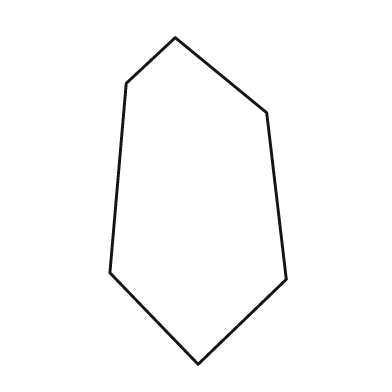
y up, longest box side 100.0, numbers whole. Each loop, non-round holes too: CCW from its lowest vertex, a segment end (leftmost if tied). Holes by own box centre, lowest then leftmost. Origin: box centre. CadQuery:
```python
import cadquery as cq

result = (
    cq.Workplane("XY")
    .moveTo(0.0, -50.0)
    .lineTo(27.0, -24.0)
    .lineTo(21.0, 27.0)
    .lineTo(-7.0, 50.0)
    .lineTo(-22.0, 36.0)
    .lineTo(-27.0, -22.0)
    .close()
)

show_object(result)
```